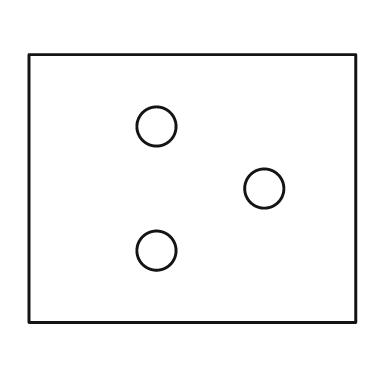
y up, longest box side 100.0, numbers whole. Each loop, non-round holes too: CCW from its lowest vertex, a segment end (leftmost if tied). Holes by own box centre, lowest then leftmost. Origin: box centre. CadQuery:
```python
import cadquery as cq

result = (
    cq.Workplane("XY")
    .moveTo(-50.0, -41.0)
    .lineTo(50.0, -41.0)
    .lineTo(50.0, 41.0)
    .lineTo(-50.0, 41.0)
    .close()
    .moveTo(-11.0, -19.0)
    .circle(6.0)
    .moveTo(22.0, 0.0)
    .circle(6.0)
    .moveTo(-11.0, 19.0)
    .circle(6.0)
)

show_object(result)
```